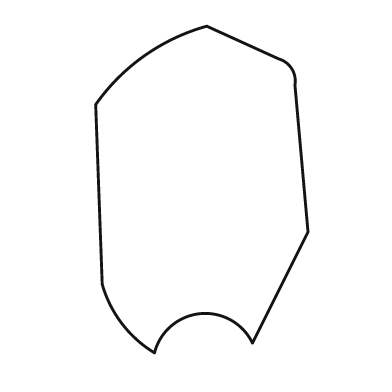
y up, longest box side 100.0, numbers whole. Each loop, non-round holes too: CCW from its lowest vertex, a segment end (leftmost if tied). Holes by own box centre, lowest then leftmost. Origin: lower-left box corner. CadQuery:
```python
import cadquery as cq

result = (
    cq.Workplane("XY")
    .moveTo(18.0, 0.0)
    .threePointArc((32.0, 12.0), (48.0, 3.0))
    .lineTo(65.0, 37.0)
    .lineTo(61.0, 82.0)
    .threePointArc((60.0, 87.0), (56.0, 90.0))
    .lineTo(34.0, 100.0)
    .threePointArc((15.0, 91.0), (0.0, 76.0))
    .lineTo(2.0, 21.0)
    .threePointArc((8.0, 9.0), (18.0, 0.0))
    .close()
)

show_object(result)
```